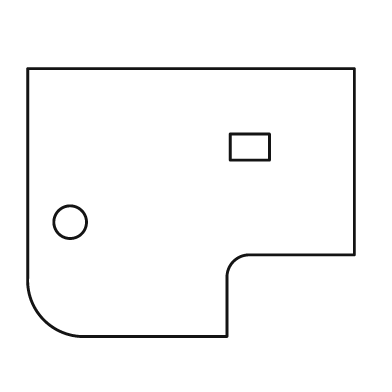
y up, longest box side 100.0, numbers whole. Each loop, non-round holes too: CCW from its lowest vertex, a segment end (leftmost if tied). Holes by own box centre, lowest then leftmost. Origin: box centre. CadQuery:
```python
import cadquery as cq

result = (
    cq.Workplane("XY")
    .moveTo(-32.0, -41.0)
    .lineTo(11.0, -41.0)
    .lineTo(11.0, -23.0)
    .threePointArc((13.0, -18.0), (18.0, -16.0))
    .lineTo(50.0, -16.0)
    .lineTo(50.0, 41.0)
    .lineTo(-50.0, 41.0)
    .lineTo(-50.0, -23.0)
    .threePointArc((-45.0, -36.0), (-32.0, -41.0))
    .close()
    .moveTo(-37.0, -6.0)
    .circle(5.0)
    .moveTo(12.0, 13.0)
    .lineTo(24.0, 13.0)
    .lineTo(24.0, 21.0)
    .lineTo(12.0, 21.0)
    .close()
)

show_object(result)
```